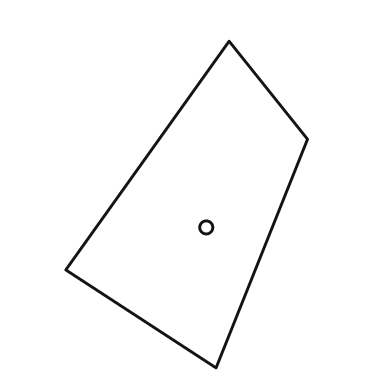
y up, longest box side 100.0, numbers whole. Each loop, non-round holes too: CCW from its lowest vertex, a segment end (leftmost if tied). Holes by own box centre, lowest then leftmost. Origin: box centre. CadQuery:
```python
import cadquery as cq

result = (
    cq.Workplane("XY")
    .moveTo(9.0, -50.0)
    .lineTo(37.0, 20.0)
    .lineTo(13.0, 50.0)
    .lineTo(-37.0, -20.0)
    .close()
    .moveTo(6.0, -7.0)
    .circle(2.0)
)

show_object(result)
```